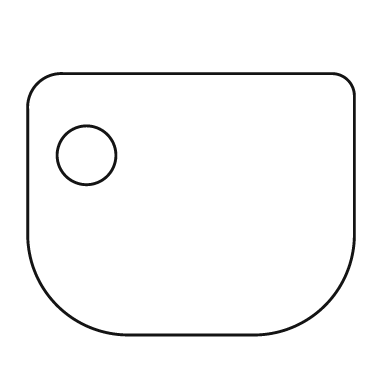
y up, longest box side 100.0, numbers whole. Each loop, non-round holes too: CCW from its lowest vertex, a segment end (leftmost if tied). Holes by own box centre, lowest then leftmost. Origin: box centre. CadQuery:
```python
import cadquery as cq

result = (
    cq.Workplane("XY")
    .moveTo(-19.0, -40.0)
    .lineTo(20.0, -40.0)
    .threePointArc((41.0, -31.0), (50.0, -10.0))
    .lineTo(50.0, 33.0)
    .threePointArc((48.0, 38.0), (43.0, 40.0))
    .lineTo(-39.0, 40.0)
    .threePointArc((-47.0, 37.0), (-50.0, 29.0))
    .lineTo(-50.0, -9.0)
    .threePointArc((-41.0, -31.0), (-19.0, -40.0))
    .close()
    .moveTo(-32.0, 15.0)
    .circle(9.0)
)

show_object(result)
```